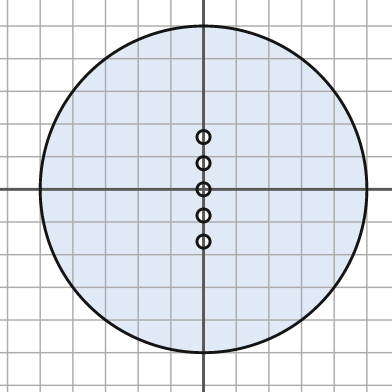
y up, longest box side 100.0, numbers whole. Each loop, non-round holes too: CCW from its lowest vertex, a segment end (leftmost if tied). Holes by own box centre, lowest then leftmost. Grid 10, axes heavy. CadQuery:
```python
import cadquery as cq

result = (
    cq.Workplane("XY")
    .moveTo(0.0, 0.0)
    .circle(50.0)
    .moveTo(0.0, -16.0)
    .circle(2.0)
    .moveTo(0.0, -8.0)
    .circle(2.0)
    .moveTo(0.0, 0.0)
    .circle(2.0)
    .moveTo(0.0, 8.0)
    .circle(2.0)
    .moveTo(0.0, 16.0)
    .circle(2.0)
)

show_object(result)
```